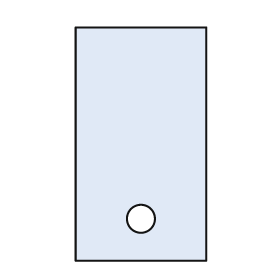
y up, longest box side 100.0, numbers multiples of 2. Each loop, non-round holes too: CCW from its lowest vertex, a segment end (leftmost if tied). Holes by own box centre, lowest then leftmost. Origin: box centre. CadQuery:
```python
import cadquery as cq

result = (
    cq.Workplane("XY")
    .moveTo(-28.0, -50.0)
    .lineTo(28.0, -50.0)
    .lineTo(28.0, 50.0)
    .lineTo(-28.0, 50.0)
    .close()
    .moveTo(0.0, -32.0)
    .circle(6.0)
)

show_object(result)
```